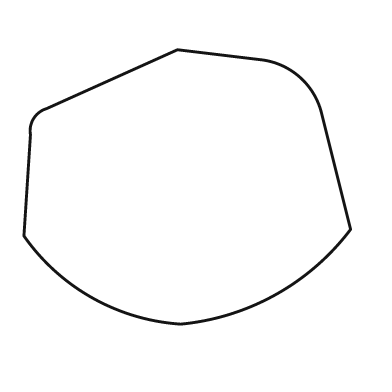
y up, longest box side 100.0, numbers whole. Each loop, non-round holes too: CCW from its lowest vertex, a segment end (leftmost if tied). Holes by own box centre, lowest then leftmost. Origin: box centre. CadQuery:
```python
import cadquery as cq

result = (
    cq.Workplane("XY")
    .moveTo(-2.0, -42.0)
    .threePointArc((27.0, -33.0), (50.0, -13.0))
    .lineTo(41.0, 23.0)
    .threePointArc((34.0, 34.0), (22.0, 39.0))
    .lineTo(-3.0, 42.0)
    .lineTo(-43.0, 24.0)
    .threePointArc((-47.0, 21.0), (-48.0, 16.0))
    .lineTo(-50.0, -15.0)
    .threePointArc((-29.0, -34.0), (-2.0, -42.0))
    .close()
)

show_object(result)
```